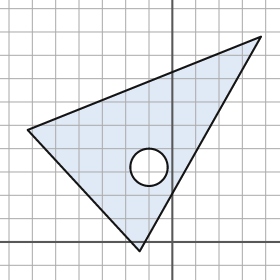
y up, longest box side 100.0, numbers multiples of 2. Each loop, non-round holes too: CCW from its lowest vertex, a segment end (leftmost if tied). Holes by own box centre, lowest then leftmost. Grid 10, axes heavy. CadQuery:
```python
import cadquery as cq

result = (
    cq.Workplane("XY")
    .moveTo(-14.0, -4.0)
    .lineTo(38.0, 88.0)
    .lineTo(-62.0, 48.0)
    .close()
    .moveTo(-10.0, 32.0)
    .circle(8.0)
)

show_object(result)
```